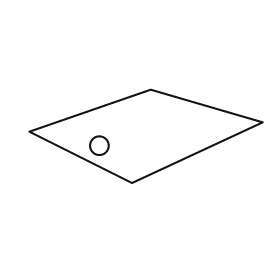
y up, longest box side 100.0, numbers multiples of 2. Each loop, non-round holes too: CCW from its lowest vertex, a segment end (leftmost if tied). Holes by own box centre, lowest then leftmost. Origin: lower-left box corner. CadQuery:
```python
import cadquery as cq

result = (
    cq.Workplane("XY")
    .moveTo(44.0, 0.0)
    .lineTo(100.0, 26.0)
    .lineTo(52.0, 40.0)
    .lineTo(0.0, 22.0)
    .close()
    .moveTo(30.0, 16.0)
    .circle(4.0)
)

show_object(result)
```